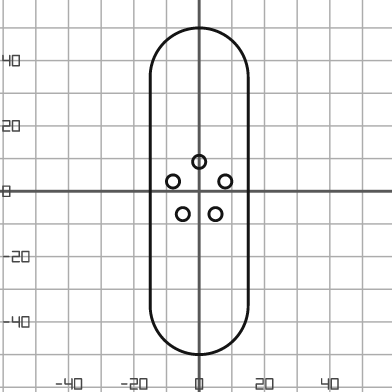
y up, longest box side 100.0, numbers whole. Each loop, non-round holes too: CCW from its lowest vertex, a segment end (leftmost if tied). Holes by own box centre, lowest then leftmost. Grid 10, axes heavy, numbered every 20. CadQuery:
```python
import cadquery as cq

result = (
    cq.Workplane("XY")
    .moveTo(-15.0, -35.0)
    .threePointArc((0.0, -50.0), (15.0, -35.0))
    .lineTo(15.0, 35.0)
    .threePointArc((0.0, 50.0), (-15.0, 35.0))
    .close()
    .moveTo(-5.0, -7.0)
    .circle(2.0)
    .moveTo(5.0, -7.0)
    .circle(2.0)
    .moveTo(-8.0, 3.0)
    .circle(2.0)
    .moveTo(8.0, 3.0)
    .circle(2.0)
    .moveTo(0.0, 9.0)
    .circle(2.0)
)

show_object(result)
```